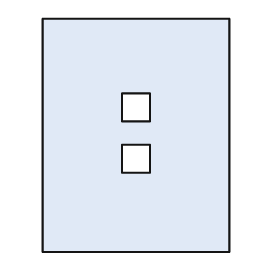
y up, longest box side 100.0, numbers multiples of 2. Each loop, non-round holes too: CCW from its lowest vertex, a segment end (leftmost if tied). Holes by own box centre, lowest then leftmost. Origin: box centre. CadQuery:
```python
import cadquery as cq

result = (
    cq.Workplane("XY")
    .moveTo(-40.0, -50.0)
    .lineTo(40.0, -50.0)
    .lineTo(40.0, 50.0)
    .lineTo(-40.0, 50.0)
    .close()
    .moveTo(-6.0, -16.0)
    .lineTo(6.0, -16.0)
    .lineTo(6.0, -4.0)
    .lineTo(-6.0, -4.0)
    .close()
    .moveTo(-6.0, 6.0)
    .lineTo(6.0, 6.0)
    .lineTo(6.0, 18.0)
    .lineTo(-6.0, 18.0)
    .close()
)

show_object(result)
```